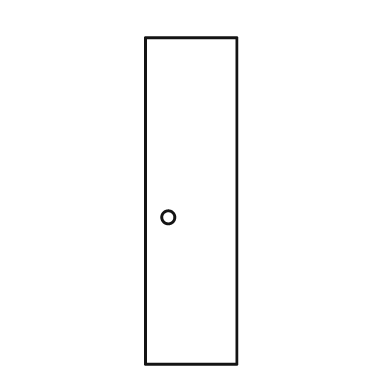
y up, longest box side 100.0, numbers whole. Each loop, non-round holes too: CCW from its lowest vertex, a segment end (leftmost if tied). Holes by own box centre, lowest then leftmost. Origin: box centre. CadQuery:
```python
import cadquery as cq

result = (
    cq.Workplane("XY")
    .moveTo(-14.0, -50.0)
    .lineTo(14.0, -50.0)
    .lineTo(14.0, 50.0)
    .lineTo(-14.0, 50.0)
    .close()
    .moveTo(-7.0, -5.0)
    .circle(2.0)
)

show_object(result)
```